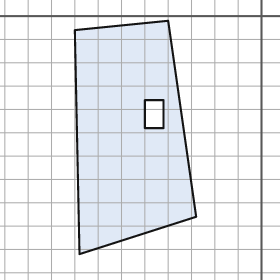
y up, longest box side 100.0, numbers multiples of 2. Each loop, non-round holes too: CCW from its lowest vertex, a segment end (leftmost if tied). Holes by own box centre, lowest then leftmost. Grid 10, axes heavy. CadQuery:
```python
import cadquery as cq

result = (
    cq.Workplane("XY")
    .moveTo(-78.0, -102.0)
    .lineTo(-28.0, -86.0)
    .lineTo(-40.0, -2.0)
    .lineTo(-80.0, -6.0)
    .close()
    .moveTo(-50.0, -48.0)
    .lineTo(-42.0, -48.0)
    .lineTo(-42.0, -36.0)
    .lineTo(-50.0, -36.0)
    .close()
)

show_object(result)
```